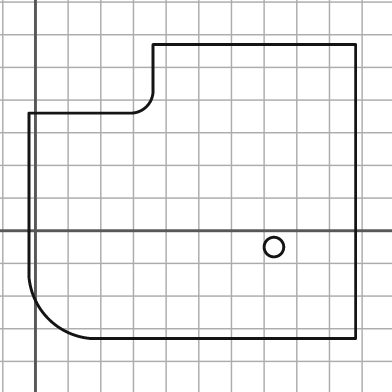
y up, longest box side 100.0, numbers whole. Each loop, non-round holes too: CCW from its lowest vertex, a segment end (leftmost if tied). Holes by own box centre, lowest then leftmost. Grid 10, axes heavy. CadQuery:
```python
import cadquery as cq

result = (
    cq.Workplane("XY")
    .moveTo(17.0, -33.0)
    .lineTo(98.0, -33.0)
    .lineTo(98.0, 57.0)
    .lineTo(36.0, 57.0)
    .lineTo(36.0, 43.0)
    .threePointArc((34.0, 38.0), (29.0, 36.0))
    .lineTo(-2.0, 36.0)
    .lineTo(-2.0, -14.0)
    .threePointArc((4.0, -27.0), (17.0, -33.0))
    .close()
    .moveTo(73.0, -5.0)
    .circle(3.0)
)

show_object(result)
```